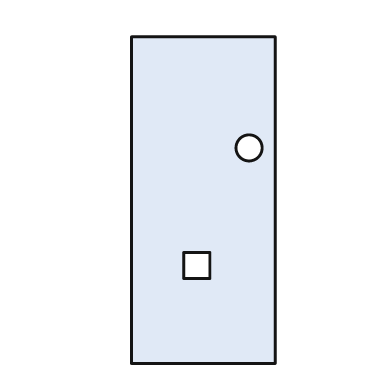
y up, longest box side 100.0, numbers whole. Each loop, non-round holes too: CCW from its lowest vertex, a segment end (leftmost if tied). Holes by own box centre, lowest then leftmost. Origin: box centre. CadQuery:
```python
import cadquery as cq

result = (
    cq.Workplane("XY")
    .moveTo(-22.0, -50.0)
    .lineTo(22.0, -50.0)
    .lineTo(22.0, 50.0)
    .lineTo(-22.0, 50.0)
    .close()
    .moveTo(-6.0, -24.0)
    .lineTo(2.0, -24.0)
    .lineTo(2.0, -16.0)
    .lineTo(-6.0, -16.0)
    .close()
    .moveTo(14.0, 16.0)
    .circle(4.0)
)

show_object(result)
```